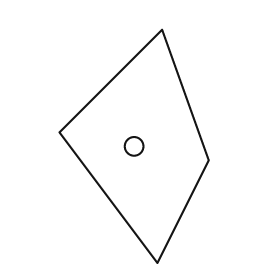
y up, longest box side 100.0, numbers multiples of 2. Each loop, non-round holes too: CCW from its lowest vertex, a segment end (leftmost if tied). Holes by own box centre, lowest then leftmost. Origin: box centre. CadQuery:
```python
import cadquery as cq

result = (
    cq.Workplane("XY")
    .moveTo(10.0, -50.0)
    .lineTo(32.0, -6.0)
    .lineTo(12.0, 50.0)
    .lineTo(-32.0, 6.0)
    .close()
    .moveTo(0.0, 0.0)
    .circle(4.0)
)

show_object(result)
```